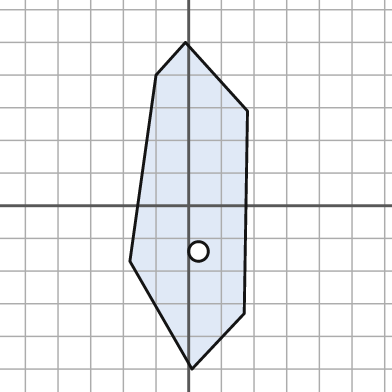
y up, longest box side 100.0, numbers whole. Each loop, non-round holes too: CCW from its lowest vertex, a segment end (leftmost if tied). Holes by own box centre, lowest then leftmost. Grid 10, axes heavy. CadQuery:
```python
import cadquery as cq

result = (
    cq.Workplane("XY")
    .moveTo(1.0, -50.0)
    .lineTo(17.0, -33.0)
    .lineTo(18.0, 29.0)
    .lineTo(-1.0, 50.0)
    .lineTo(-10.0, 40.0)
    .lineTo(-18.0, -17.0)
    .close()
    .moveTo(3.0, -14.0)
    .circle(3.0)
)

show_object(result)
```